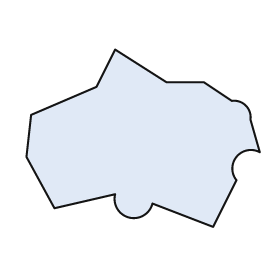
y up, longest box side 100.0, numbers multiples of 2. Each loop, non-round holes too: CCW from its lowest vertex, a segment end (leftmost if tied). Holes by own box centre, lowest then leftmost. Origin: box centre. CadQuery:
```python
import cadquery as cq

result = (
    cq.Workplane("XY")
    .moveTo(30.0, -38.0)
    .lineTo(40.0, -18.0)
    .threePointArc((40.0, -8.0), (50.0, -6.0))
    .lineTo(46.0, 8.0)
    .threePointArc((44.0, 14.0), (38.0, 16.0))
    .lineTo(26.0, 24.0)
    .lineTo(10.0, 24.0)
    .lineTo(-12.0, 38.0)
    .lineTo(-20.0, 22.0)
    .lineTo(-48.0, 10.0)
    .lineTo(-50.0, -8.0)
    .lineTo(-38.0, -30.0)
    .lineTo(-12.0, -24.0)
    .threePointArc((-6.0, -34.0), (4.0, -28.0))
    .close()
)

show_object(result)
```